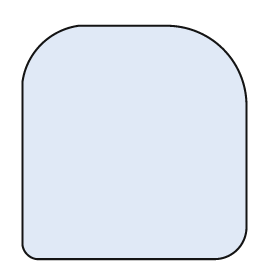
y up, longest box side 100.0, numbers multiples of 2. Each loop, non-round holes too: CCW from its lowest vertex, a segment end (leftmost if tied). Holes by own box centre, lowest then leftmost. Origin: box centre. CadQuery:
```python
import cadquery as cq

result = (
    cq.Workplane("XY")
    .moveTo(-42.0, -50.0)
    .lineTo(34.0, -50.0)
    .threePointArc((44.0, -46.0), (48.0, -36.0))
    .lineTo(48.0, 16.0)
    .threePointArc((38.0, 40.0), (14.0, 50.0))
    .lineTo(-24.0, 50.0)
    .threePointArc((-40.0, 42.0), (-48.0, 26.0))
    .lineTo(-48.0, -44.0)
    .threePointArc((-46.0, -48.0), (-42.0, -50.0))
    .close()
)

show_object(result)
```